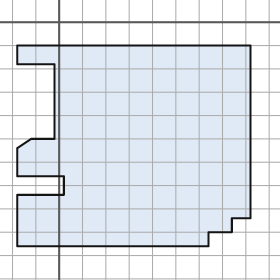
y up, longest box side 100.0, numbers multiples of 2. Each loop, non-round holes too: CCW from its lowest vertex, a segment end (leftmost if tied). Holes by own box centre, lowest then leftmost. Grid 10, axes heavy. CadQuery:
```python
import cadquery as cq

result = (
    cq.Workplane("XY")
    .moveTo(-18.0, -96.0)
    .lineTo(64.0, -96.0)
    .lineTo(64.0, -90.0)
    .lineTo(74.0, -90.0)
    .lineTo(74.0, -84.0)
    .lineTo(82.0, -84.0)
    .lineTo(82.0, -10.0)
    .lineTo(-18.0, -10.0)
    .lineTo(-18.0, -18.0)
    .lineTo(-2.0, -18.0)
    .lineTo(-2.0, -50.0)
    .lineTo(-12.0, -50.0)
    .lineTo(-18.0, -54.0)
    .lineTo(-18.0, -66.0)
    .lineTo(2.0, -66.0)
    .lineTo(2.0, -74.0)
    .lineTo(-18.0, -74.0)
    .close()
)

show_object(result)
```